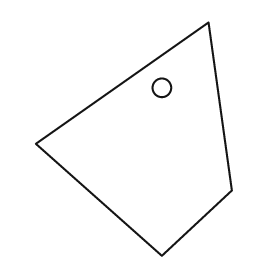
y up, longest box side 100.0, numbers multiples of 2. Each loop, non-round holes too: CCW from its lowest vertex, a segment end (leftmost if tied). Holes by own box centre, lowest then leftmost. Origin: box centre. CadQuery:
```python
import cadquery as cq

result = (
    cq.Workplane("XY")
    .moveTo(12.0, -50.0)
    .lineTo(42.0, -22.0)
    .lineTo(32.0, 50.0)
    .lineTo(-42.0, -2.0)
    .close()
    .moveTo(12.0, 22.0)
    .circle(4.0)
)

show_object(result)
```